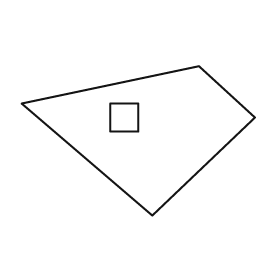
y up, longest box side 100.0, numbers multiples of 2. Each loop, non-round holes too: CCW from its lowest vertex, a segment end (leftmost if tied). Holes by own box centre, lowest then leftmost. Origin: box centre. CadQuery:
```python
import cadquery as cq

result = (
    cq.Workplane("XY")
    .moveTo(6.0, -32.0)
    .lineTo(50.0, 10.0)
    .lineTo(26.0, 32.0)
    .lineTo(-50.0, 16.0)
    .close()
    .moveTo(-12.0, 4.0)
    .lineTo(0.0, 4.0)
    .lineTo(0.0, 16.0)
    .lineTo(-12.0, 16.0)
    .close()
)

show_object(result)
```